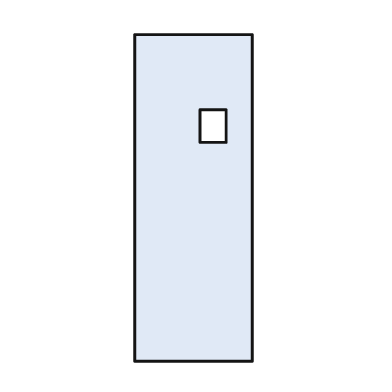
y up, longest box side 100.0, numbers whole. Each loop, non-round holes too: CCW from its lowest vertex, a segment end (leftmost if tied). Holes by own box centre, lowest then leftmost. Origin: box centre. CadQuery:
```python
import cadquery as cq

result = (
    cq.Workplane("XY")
    .moveTo(-18.0, -50.0)
    .lineTo(18.0, -50.0)
    .lineTo(18.0, 50.0)
    .lineTo(-18.0, 50.0)
    .close()
    .moveTo(2.0, 17.0)
    .lineTo(10.0, 17.0)
    .lineTo(10.0, 27.0)
    .lineTo(2.0, 27.0)
    .close()
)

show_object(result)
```